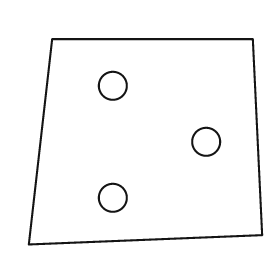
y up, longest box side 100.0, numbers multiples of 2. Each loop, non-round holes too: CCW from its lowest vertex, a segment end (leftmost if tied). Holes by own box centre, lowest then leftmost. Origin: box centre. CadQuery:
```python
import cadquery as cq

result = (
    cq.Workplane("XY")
    .moveTo(-50.0, -44.0)
    .lineTo(50.0, -40.0)
    .lineTo(46.0, 44.0)
    .lineTo(-40.0, 44.0)
    .close()
    .moveTo(-14.0, -24.0)
    .circle(6.0)
    .moveTo(26.0, 0.0)
    .circle(6.0)
    .moveTo(-14.0, 24.0)
    .circle(6.0)
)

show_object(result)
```